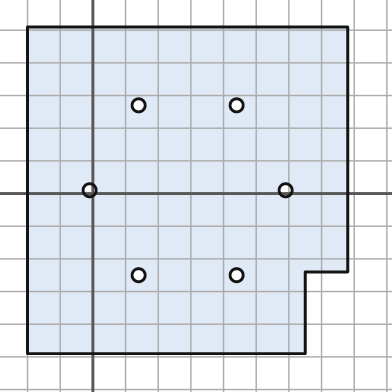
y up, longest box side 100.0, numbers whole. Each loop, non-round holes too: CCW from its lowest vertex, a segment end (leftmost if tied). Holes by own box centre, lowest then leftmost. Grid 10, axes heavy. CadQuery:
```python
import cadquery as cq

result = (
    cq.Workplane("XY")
    .moveTo(-20.0, -49.0)
    .lineTo(65.0, -49.0)
    .lineTo(65.0, -24.0)
    .lineTo(78.0, -24.0)
    .lineTo(78.0, 51.0)
    .lineTo(-20.0, 51.0)
    .close()
    .moveTo(14.0, -25.0)
    .circle(2.0)
    .moveTo(44.0, -25.0)
    .circle(2.0)
    .moveTo(-1.0, 1.0)
    .circle(2.0)
    .moveTo(59.0, 1.0)
    .circle(2.0)
    .moveTo(14.0, 27.0)
    .circle(2.0)
    .moveTo(44.0, 27.0)
    .circle(2.0)
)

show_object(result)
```